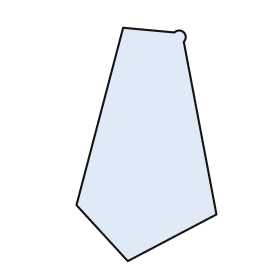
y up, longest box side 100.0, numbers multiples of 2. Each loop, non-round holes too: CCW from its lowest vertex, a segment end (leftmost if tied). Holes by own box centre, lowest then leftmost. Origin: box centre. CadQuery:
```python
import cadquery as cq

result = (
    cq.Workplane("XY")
    .moveTo(-8.0, -50.0)
    .lineTo(30.0, -30.0)
    .lineTo(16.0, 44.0)
    .threePointArc((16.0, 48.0), (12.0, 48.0))
    .lineTo(-10.0, 50.0)
    .lineTo(-30.0, -26.0)
    .close()
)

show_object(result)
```